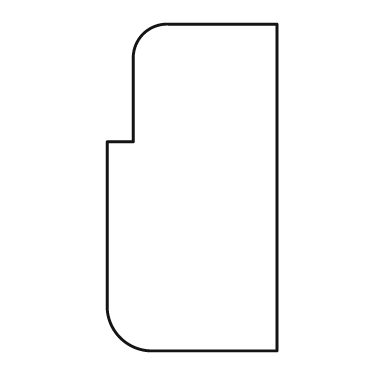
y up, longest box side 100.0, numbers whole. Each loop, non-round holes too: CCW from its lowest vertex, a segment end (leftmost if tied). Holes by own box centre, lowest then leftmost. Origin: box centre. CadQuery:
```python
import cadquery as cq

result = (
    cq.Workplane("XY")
    .moveTo(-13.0, -50.0)
    .lineTo(26.0, -50.0)
    .lineTo(26.0, 50.0)
    .lineTo(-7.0, 50.0)
    .threePointArc((-15.0, 47.0), (-18.0, 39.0))
    .lineTo(-18.0, 14.0)
    .lineTo(-26.0, 14.0)
    .lineTo(-26.0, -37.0)
    .threePointArc((-22.0, -46.0), (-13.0, -50.0))
    .close()
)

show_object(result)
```